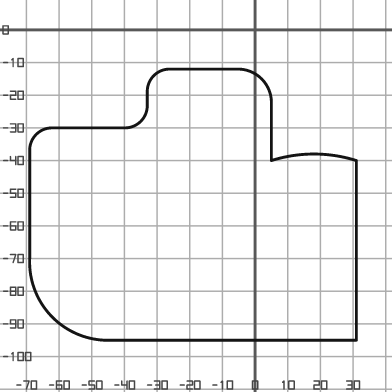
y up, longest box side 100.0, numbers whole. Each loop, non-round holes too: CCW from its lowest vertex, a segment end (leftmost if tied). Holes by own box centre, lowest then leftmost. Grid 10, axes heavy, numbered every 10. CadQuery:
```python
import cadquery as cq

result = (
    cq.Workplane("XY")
    .moveTo(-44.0, -95.0)
    .lineTo(31.0, -95.0)
    .lineTo(31.0, -40.0)
    .threePointArc((18.0, -38.0), (5.0, -40.0))
    .lineTo(5.0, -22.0)
    .threePointArc((2.0, -15.0), (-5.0, -12.0))
    .lineTo(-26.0, -12.0)
    .threePointArc((-31.0, -14.0), (-33.0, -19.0))
    .lineTo(-33.0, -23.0)
    .threePointArc((-35.0, -28.0), (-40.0, -30.0))
    .lineTo(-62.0, -30.0)
    .threePointArc((-67.0, -32.0), (-69.0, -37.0))
    .lineTo(-69.0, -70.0)
    .threePointArc((-62.0, -88.0), (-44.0, -95.0))
    .close()
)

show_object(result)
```